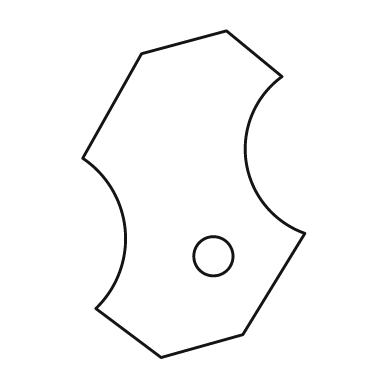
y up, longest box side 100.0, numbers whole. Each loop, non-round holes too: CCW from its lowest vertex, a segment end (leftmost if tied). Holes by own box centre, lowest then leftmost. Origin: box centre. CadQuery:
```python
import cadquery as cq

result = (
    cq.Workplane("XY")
    .moveTo(-10.0, -50.0)
    .lineTo(15.0, -43.0)
    .lineTo(34.0, -12.0)
    .threePointArc((16.0, 10.0), (27.0, 36.0))
    .lineTo(10.0, 50.0)
    .lineTo(-16.0, 43.0)
    .lineTo(-34.0, 11.0)
    .threePointArc((-21.0, -11.0), (-30.0, -35.0))
    .close()
    .moveTo(6.0, -19.0)
    .circle(6.0)
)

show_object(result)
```